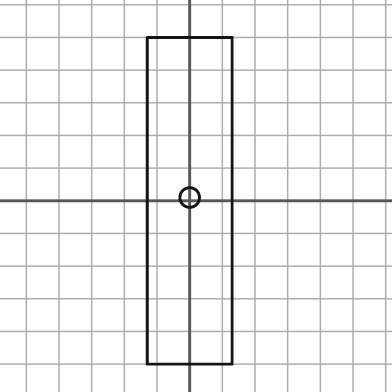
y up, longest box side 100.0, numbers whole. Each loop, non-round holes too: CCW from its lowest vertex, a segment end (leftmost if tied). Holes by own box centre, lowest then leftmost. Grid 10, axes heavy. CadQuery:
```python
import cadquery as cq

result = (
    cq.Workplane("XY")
    .moveTo(-13.0, -50.0)
    .lineTo(13.0, -50.0)
    .lineTo(13.0, 50.0)
    .lineTo(-13.0, 50.0)
    .close()
    .moveTo(0.0, 1.0)
    .circle(3.0)
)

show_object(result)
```